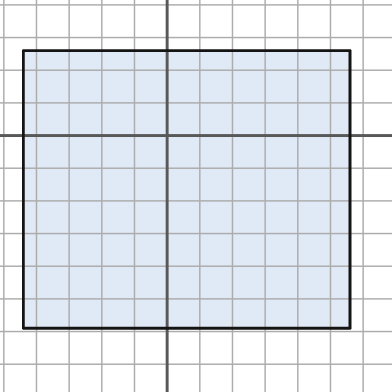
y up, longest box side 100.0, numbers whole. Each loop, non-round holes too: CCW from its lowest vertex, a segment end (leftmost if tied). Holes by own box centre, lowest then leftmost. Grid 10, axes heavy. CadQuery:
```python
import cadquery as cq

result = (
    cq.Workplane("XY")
    .moveTo(-44.0, -59.0)
    .lineTo(56.0, -59.0)
    .lineTo(56.0, 26.0)
    .lineTo(-44.0, 26.0)
    .close()
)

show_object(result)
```